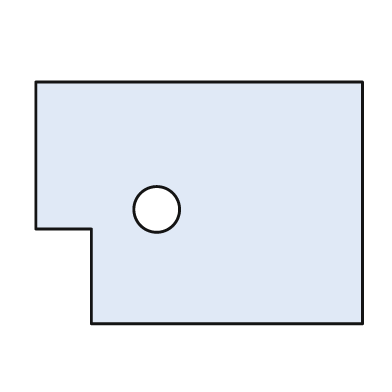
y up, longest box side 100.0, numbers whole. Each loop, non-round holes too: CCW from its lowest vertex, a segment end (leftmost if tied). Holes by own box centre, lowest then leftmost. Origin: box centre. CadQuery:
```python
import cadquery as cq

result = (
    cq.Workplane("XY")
    .moveTo(-33.0, -37.0)
    .lineTo(50.0, -37.0)
    .lineTo(50.0, 37.0)
    .lineTo(-50.0, 37.0)
    .lineTo(-50.0, -8.0)
    .lineTo(-33.0, -8.0)
    .close()
    .moveTo(-13.0, -2.0)
    .circle(7.0)
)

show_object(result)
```